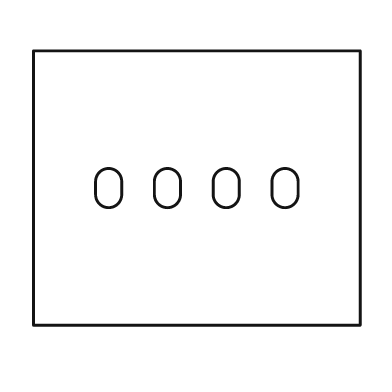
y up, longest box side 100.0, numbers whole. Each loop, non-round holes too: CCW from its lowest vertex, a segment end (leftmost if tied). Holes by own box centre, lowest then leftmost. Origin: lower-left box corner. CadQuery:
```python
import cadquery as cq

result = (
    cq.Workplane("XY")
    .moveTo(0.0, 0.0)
    .lineTo(100.0, 0.0)
    .lineTo(100.0, 84.0)
    .lineTo(0.0, 84.0)
    .close()
    .moveTo(19.0, 40.0)
    .threePointArc((23.0, 36.0), (27.0, 40.0))
    .lineTo(27.0, 44.0)
    .threePointArc((23.0, 48.0), (19.0, 44.0))
    .close()
    .moveTo(37.0, 40.0)
    .threePointArc((41.0, 36.0), (45.0, 40.0))
    .lineTo(45.0, 44.0)
    .threePointArc((41.0, 48.0), (37.0, 44.0))
    .close()
    .moveTo(55.0, 40.0)
    .threePointArc((59.0, 36.0), (63.0, 40.0))
    .lineTo(63.0, 44.0)
    .threePointArc((59.0, 48.0), (55.0, 44.0))
    .close()
    .moveTo(73.0, 40.0)
    .threePointArc((77.0, 36.0), (81.0, 40.0))
    .lineTo(81.0, 44.0)
    .threePointArc((77.0, 48.0), (73.0, 44.0))
    .close()
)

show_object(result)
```